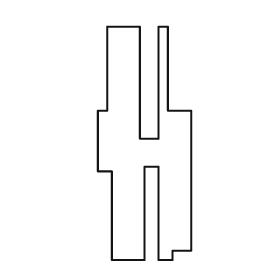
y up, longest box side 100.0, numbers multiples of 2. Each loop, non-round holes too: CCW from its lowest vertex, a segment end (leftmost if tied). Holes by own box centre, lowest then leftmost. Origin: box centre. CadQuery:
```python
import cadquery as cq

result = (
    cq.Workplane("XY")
    .moveTo(-14.0, -50.0)
    .lineTo(0.0, -50.0)
    .lineTo(0.0, -10.0)
    .lineTo(6.0, -10.0)
    .lineTo(6.0, -50.0)
    .lineTo(12.0, -50.0)
    .lineTo(12.0, -46.0)
    .lineTo(20.0, -46.0)
    .lineTo(20.0, 14.0)
    .lineTo(10.0, 14.0)
    .lineTo(10.0, 50.0)
    .lineTo(6.0, 50.0)
    .lineTo(6.0, 2.0)
    .lineTo(-2.0, 2.0)
    .lineTo(-2.0, 50.0)
    .lineTo(-16.0, 50.0)
    .lineTo(-16.0, 14.0)
    .lineTo(-20.0, 14.0)
    .lineTo(-20.0, -12.0)
    .lineTo(-14.0, -12.0)
    .close()
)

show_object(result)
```